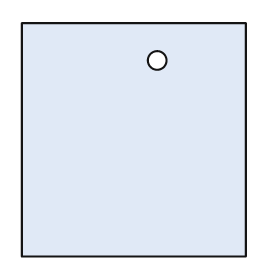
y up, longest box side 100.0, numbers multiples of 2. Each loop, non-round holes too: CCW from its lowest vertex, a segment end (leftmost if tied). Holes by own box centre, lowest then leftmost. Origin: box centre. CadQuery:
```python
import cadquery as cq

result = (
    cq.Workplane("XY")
    .moveTo(-48.0, -50.0)
    .lineTo(48.0, -50.0)
    .lineTo(48.0, 50.0)
    .lineTo(-48.0, 50.0)
    .close()
    .moveTo(10.0, 34.0)
    .circle(4.0)
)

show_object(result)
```